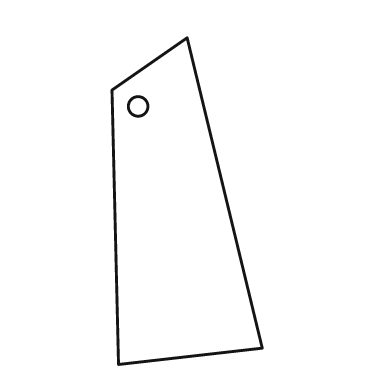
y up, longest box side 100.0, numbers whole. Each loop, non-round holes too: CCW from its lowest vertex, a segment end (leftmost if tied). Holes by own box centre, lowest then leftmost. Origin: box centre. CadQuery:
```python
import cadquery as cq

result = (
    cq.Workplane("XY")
    .moveTo(-21.0, -50.0)
    .lineTo(23.0, -45.0)
    .lineTo(0.0, 50.0)
    .lineTo(-23.0, 34.0)
    .close()
    .moveTo(-15.0, 29.0)
    .circle(3.0)
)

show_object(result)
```